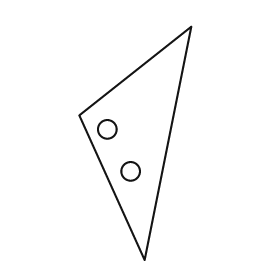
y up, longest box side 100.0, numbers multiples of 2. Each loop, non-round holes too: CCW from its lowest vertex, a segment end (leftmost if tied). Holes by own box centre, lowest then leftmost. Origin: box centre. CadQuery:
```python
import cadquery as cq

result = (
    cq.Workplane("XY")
    .moveTo(4.0, -50.0)
    .lineTo(24.0, 50.0)
    .lineTo(-24.0, 12.0)
    .close()
    .moveTo(-2.0, -12.0)
    .circle(4.0)
    .moveTo(-12.0, 6.0)
    .circle(4.0)
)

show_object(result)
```